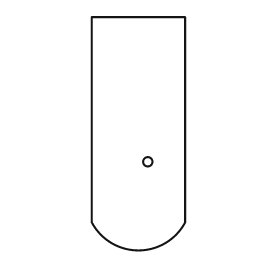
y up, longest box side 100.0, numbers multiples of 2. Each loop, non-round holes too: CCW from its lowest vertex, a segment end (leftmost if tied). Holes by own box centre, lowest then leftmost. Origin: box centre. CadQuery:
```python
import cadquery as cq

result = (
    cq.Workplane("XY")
    .moveTo(-20.0, -38.0)
    .threePointArc((0.0, -50.0), (20.0, -38.0))
    .lineTo(20.0, 50.0)
    .lineTo(-20.0, 50.0)
    .close()
    .moveTo(4.0, -12.0)
    .circle(2.0)
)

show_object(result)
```